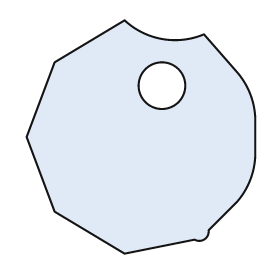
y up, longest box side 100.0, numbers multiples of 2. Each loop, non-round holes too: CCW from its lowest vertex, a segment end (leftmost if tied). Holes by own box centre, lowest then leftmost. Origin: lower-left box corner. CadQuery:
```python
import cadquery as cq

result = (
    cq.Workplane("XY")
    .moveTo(42.0, 0.0)
    .lineTo(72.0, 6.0)
    .threePointArc((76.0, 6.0), (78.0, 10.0))
    .lineTo(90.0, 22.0)
    .threePointArc((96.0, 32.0), (98.0, 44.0))
    .lineTo(98.0, 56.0)
    .threePointArc((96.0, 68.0), (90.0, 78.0))
    .lineTo(76.0, 94.0)
    .threePointArc((58.0, 92.0), (42.0, 100.0))
    .lineTo(12.0, 82.0)
    .lineTo(0.0, 50.0)
    .lineTo(12.0, 18.0)
    .close()
    .moveTo(58.0, 72.0)
    .circle(10.0)
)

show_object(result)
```